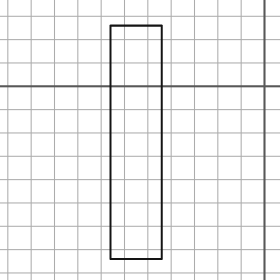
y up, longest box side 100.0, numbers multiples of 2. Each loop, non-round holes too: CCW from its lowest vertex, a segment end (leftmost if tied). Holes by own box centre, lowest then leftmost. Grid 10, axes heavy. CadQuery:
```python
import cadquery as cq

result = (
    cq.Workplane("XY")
    .moveTo(-66.0, -74.0)
    .lineTo(-44.0, -74.0)
    .lineTo(-44.0, 26.0)
    .lineTo(-66.0, 26.0)
    .close()
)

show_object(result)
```